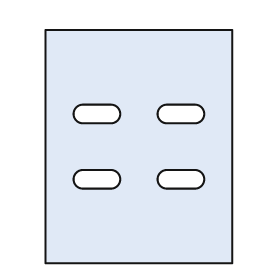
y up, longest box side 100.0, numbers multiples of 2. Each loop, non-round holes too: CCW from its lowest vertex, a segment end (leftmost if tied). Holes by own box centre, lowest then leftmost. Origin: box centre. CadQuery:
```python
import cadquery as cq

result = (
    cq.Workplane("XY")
    .moveTo(-40.0, -50.0)
    .lineTo(40.0, -50.0)
    .lineTo(40.0, 50.0)
    .lineTo(-40.0, 50.0)
    .close()
    .moveTo(-24.0, -18.0)
    .lineTo(-12.0, -18.0)
    .threePointArc((-8.0, -14.0), (-12.0, -10.0))
    .lineTo(-24.0, -10.0)
    .threePointArc((-28.0, -14.0), (-24.0, -18.0))
    .close()
    .moveTo(12.0, -18.0)
    .lineTo(24.0, -18.0)
    .threePointArc((28.0, -14.0), (24.0, -10.0))
    .lineTo(12.0, -10.0)
    .threePointArc((8.0, -14.0), (12.0, -18.0))
    .close()
    .moveTo(-24.0, 10.0)
    .lineTo(-12.0, 10.0)
    .threePointArc((-8.0, 14.0), (-12.0, 18.0))
    .lineTo(-24.0, 18.0)
    .threePointArc((-28.0, 14.0), (-24.0, 10.0))
    .close()
    .moveTo(12.0, 10.0)
    .lineTo(24.0, 10.0)
    .threePointArc((28.0, 14.0), (24.0, 18.0))
    .lineTo(12.0, 18.0)
    .threePointArc((8.0, 14.0), (12.0, 10.0))
    .close()
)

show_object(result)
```